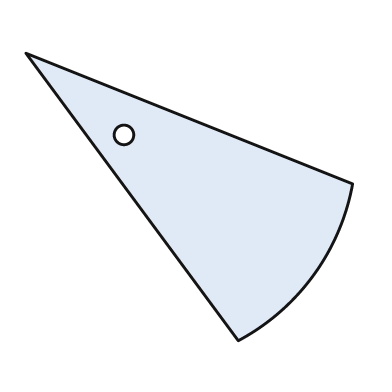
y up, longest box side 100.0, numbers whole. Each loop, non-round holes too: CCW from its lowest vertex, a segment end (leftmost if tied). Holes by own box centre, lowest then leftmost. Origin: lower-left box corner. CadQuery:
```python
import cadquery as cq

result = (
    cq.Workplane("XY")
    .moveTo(65.0, 0.0)
    .threePointArc((88.0, 20.0), (100.0, 48.0))
    .lineTo(0.0, 88.0)
    .close()
    .moveTo(30.0, 63.0)
    .circle(3.0)
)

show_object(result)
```